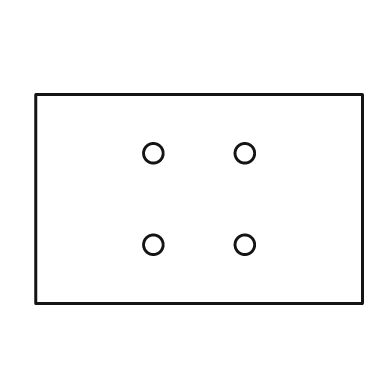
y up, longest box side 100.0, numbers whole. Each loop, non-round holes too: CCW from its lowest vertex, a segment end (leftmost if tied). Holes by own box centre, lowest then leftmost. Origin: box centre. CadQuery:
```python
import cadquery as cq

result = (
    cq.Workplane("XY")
    .moveTo(-50.0, -32.0)
    .lineTo(50.0, -32.0)
    .lineTo(50.0, 32.0)
    .lineTo(-50.0, 32.0)
    .close()
    .moveTo(-14.0, -14.0)
    .circle(3.0)
    .moveTo(14.0, -14.0)
    .circle(3.0)
    .moveTo(-14.0, 14.0)
    .circle(3.0)
    .moveTo(14.0, 14.0)
    .circle(3.0)
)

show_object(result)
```